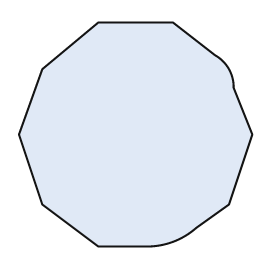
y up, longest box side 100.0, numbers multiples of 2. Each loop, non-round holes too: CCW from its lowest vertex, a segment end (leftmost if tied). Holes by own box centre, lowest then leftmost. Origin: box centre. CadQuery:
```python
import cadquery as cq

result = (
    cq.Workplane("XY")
    .moveTo(-16.0, -48.0)
    .lineTo(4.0, -48.0)
    .threePointArc((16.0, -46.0), (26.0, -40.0))
    .lineTo(40.0, -30.0)
    .lineTo(50.0, 0.0)
    .lineTo(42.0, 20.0)
    .threePointArc((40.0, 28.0), (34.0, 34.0))
    .lineTo(16.0, 48.0)
    .lineTo(-16.0, 48.0)
    .lineTo(-40.0, 28.0)
    .lineTo(-50.0, 0.0)
    .lineTo(-40.0, -30.0)
    .close()
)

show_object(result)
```